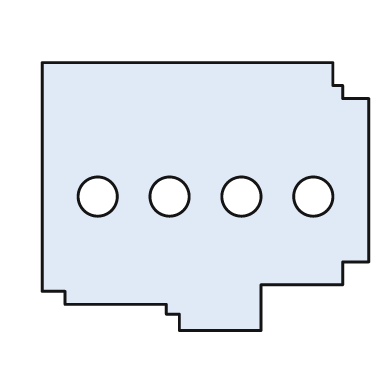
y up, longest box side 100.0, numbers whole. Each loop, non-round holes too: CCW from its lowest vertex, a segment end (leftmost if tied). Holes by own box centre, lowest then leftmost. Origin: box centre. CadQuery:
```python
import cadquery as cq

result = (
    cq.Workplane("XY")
    .moveTo(-8.0, -41.0)
    .lineTo(17.0, -41.0)
    .lineTo(17.0, -27.0)
    .lineTo(42.0, -27.0)
    .lineTo(42.0, -20.0)
    .lineTo(50.0, -20.0)
    .lineTo(50.0, 30.0)
    .lineTo(42.0, 30.0)
    .lineTo(42.0, 34.0)
    .lineTo(39.0, 34.0)
    .lineTo(39.0, 41.0)
    .lineTo(-50.0, 41.0)
    .lineTo(-50.0, -29.0)
    .lineTo(-43.0, -29.0)
    .lineTo(-43.0, -33.0)
    .lineTo(-12.0, -33.0)
    .lineTo(-12.0, -36.0)
    .lineTo(-8.0, -36.0)
    .close()
    .moveTo(-33.0, 0.0)
    .circle(6.0)
    .moveTo(-11.0, 0.0)
    .circle(6.0)
    .moveTo(11.0, 0.0)
    .circle(6.0)
    .moveTo(33.0, 0.0)
    .circle(6.0)
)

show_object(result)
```